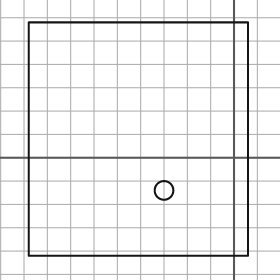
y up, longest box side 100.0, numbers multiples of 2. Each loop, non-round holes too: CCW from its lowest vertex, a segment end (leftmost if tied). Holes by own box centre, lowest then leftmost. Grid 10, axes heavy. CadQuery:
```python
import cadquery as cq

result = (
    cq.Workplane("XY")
    .moveTo(-88.0, -42.0)
    .lineTo(6.0, -42.0)
    .lineTo(6.0, 58.0)
    .lineTo(-88.0, 58.0)
    .close()
    .moveTo(-30.0, -14.0)
    .circle(4.0)
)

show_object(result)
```